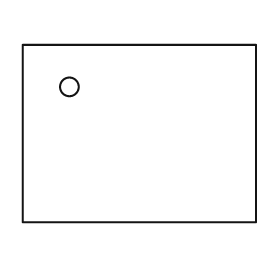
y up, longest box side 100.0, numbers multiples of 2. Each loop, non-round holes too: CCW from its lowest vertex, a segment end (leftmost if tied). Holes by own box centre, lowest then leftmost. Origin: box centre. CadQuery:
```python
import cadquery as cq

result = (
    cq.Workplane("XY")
    .moveTo(-50.0, -38.0)
    .lineTo(50.0, -38.0)
    .lineTo(50.0, 38.0)
    .lineTo(-50.0, 38.0)
    .close()
    .moveTo(-30.0, 20.0)
    .circle(4.0)
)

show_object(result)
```